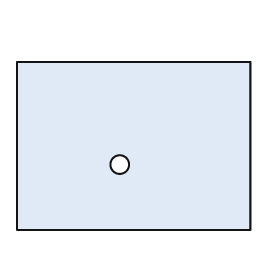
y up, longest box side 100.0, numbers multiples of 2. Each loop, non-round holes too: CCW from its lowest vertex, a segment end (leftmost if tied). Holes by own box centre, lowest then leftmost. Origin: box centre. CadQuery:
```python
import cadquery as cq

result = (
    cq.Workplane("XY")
    .moveTo(-50.0, -36.0)
    .lineTo(50.0, -36.0)
    .lineTo(50.0, 36.0)
    .lineTo(-50.0, 36.0)
    .close()
    .moveTo(-6.0, -8.0)
    .circle(4.0)
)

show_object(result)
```